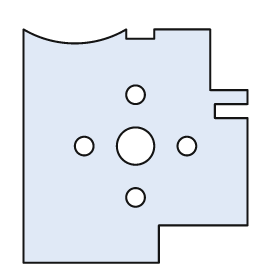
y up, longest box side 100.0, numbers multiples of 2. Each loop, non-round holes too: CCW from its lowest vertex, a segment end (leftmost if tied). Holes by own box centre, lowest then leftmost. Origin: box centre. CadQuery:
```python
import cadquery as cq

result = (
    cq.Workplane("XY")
    .moveTo(-48.0, -50.0)
    .lineTo(10.0, -50.0)
    .lineTo(10.0, -34.0)
    .lineTo(48.0, -34.0)
    .lineTo(48.0, 12.0)
    .lineTo(34.0, 12.0)
    .lineTo(34.0, 18.0)
    .lineTo(48.0, 18.0)
    .lineTo(48.0, 24.0)
    .lineTo(32.0, 24.0)
    .lineTo(32.0, 50.0)
    .lineTo(8.0, 50.0)
    .lineTo(8.0, 46.0)
    .lineTo(-4.0, 46.0)
    .lineTo(-4.0, 50.0)
    .threePointArc((-26.0, 44.0), (-48.0, 50.0))
    .close()
    .moveTo(0.0, -22.0)
    .circle(4.0)
    .moveTo(-22.0, 0.0)
    .circle(4.0)
    .moveTo(0.0, 0.0)
    .circle(8.0)
    .moveTo(22.0, 0.0)
    .circle(4.0)
    .moveTo(0.0, 22.0)
    .circle(4.0)
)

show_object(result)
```